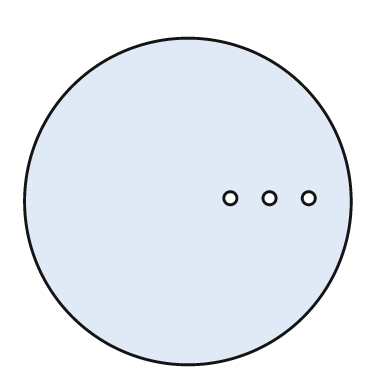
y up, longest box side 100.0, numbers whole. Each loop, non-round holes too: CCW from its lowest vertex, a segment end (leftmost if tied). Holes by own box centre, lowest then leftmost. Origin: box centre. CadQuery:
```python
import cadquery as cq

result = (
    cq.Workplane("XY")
    .moveTo(0.0, 0.0)
    .circle(50.0)
    .moveTo(13.0, 1.0)
    .circle(2.0)
    .moveTo(25.0, 1.0)
    .circle(2.0)
    .moveTo(37.0, 1.0)
    .circle(2.0)
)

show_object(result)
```